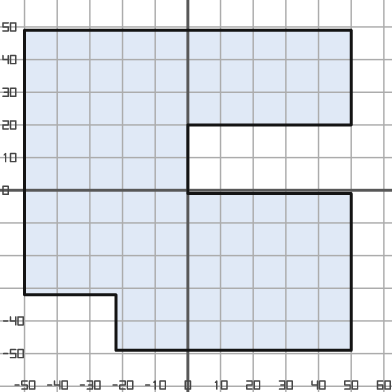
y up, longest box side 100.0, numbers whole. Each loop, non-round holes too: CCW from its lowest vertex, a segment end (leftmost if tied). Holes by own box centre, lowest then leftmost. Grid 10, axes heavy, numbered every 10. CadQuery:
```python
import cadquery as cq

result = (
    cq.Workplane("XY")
    .moveTo(-22.0, -49.0)
    .lineTo(50.0, -49.0)
    .lineTo(50.0, -1.0)
    .lineTo(0.0, -1.0)
    .lineTo(0.0, 20.0)
    .lineTo(50.0, 20.0)
    .lineTo(50.0, 49.0)
    .lineTo(-50.0, 49.0)
    .lineTo(-50.0, -32.0)
    .lineTo(-22.0, -32.0)
    .close()
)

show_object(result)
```